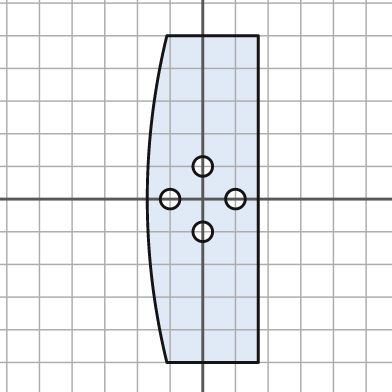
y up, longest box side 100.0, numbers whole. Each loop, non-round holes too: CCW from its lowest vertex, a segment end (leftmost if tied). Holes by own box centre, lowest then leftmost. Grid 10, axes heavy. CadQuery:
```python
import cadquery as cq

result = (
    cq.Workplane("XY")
    .moveTo(-11.0, -50.0)
    .lineTo(17.0, -50.0)
    .lineTo(17.0, 50.0)
    .lineTo(-11.0, 50.0)
    .threePointArc((-17.0, 0.0), (-11.0, -50.0))
    .close()
    .moveTo(0.0, -10.0)
    .circle(3.0)
    .moveTo(-10.0, 0.0)
    .circle(3.0)
    .moveTo(10.0, 0.0)
    .circle(3.0)
    .moveTo(0.0, 10.0)
    .circle(3.0)
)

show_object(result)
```